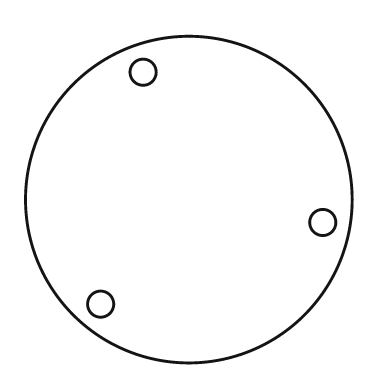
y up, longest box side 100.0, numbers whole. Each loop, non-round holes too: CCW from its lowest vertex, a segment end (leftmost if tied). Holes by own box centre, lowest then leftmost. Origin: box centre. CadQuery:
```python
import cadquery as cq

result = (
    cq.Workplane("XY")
    .moveTo(0.0, 0.0)
    .circle(50.0)
    .moveTo(-27.0, -32.0)
    .circle(4.0)
    .moveTo(41.0, -7.0)
    .circle(4.0)
    .moveTo(-14.0, 39.0)
    .circle(4.0)
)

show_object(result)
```